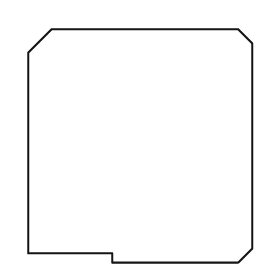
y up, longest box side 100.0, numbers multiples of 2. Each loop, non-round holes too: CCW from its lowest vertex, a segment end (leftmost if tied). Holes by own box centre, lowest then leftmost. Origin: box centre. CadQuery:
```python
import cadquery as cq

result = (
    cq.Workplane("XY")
    .moveTo(-12.0, -50.0)
    .lineTo(42.0, -50.0)
    .lineTo(48.0, -44.0)
    .lineTo(48.0, 44.0)
    .lineTo(42.0, 50.0)
    .lineTo(-38.0, 50.0)
    .lineTo(-48.0, 40.0)
    .lineTo(-48.0, -46.0)
    .lineTo(-12.0, -46.0)
    .close()
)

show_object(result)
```